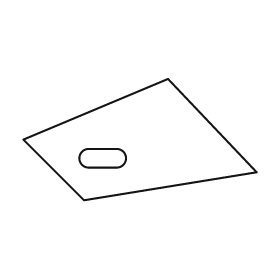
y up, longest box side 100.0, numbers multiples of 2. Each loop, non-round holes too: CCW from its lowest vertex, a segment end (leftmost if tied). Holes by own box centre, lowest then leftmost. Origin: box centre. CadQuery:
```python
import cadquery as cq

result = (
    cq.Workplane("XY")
    .moveTo(-24.0, -26.0)
    .lineTo(50.0, -14.0)
    .lineTo(12.0, 26.0)
    .lineTo(-50.0, 0.0)
    .close()
    .moveTo(-22.0, -12.0)
    .lineTo(-10.0, -12.0)
    .threePointArc((-6.0, -8.0), (-10.0, -4.0))
    .lineTo(-22.0, -4.0)
    .threePointArc((-26.0, -8.0), (-22.0, -12.0))
    .close()
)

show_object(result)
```